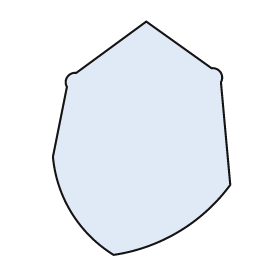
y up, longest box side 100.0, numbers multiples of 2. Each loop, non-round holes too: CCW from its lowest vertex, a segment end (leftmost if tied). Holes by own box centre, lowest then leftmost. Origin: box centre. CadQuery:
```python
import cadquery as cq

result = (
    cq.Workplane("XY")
    .moveTo(-12.0, -50.0)
    .threePointArc((16.0, -40.0), (38.0, -20.0))
    .lineTo(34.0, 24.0)
    .threePointArc((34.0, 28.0), (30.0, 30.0))
    .lineTo(2.0, 50.0)
    .lineTo(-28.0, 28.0)
    .threePointArc((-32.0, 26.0), (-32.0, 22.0))
    .lineTo(-38.0, -8.0)
    .threePointArc((-30.0, -32.0), (-12.0, -50.0))
    .close()
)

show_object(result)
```